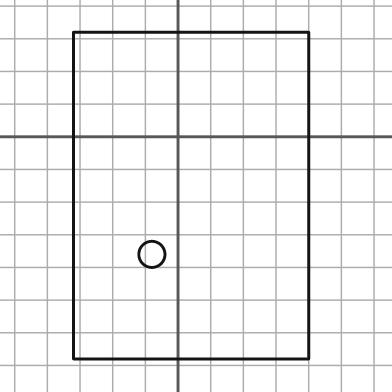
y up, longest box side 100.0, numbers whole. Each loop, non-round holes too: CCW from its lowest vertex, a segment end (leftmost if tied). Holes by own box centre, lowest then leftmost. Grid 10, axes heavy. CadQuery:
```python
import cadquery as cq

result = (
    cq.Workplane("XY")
    .moveTo(-32.0, -68.0)
    .lineTo(40.0, -68.0)
    .lineTo(40.0, 32.0)
    .lineTo(-32.0, 32.0)
    .close()
    .moveTo(-8.0, -36.0)
    .circle(4.0)
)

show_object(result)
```